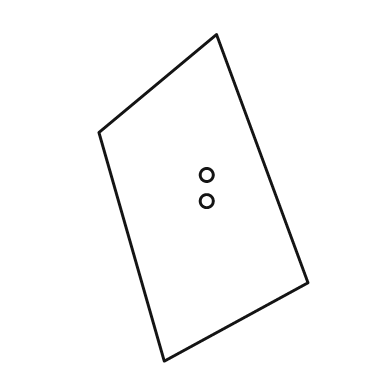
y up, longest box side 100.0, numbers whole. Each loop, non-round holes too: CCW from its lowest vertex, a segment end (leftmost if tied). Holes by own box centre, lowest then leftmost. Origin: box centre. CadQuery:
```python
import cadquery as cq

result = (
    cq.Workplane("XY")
    .moveTo(-12.0, -50.0)
    .lineTo(32.0, -26.0)
    .lineTo(4.0, 50.0)
    .lineTo(-32.0, 20.0)
    .close()
    .moveTo(1.0, -1.0)
    .circle(2.0)
    .moveTo(1.0, 7.0)
    .circle(2.0)
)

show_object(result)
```